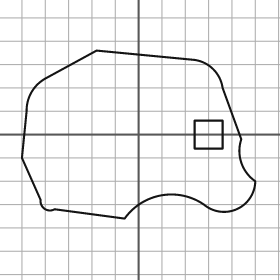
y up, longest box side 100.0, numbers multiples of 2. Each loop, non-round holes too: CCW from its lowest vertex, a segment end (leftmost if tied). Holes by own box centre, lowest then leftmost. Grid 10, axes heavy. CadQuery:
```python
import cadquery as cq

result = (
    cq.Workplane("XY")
    .moveTo(-6.0, -36.0)
    .threePointArc((10.0, -26.0), (28.0, -30.0))
    .threePointArc((42.0, -32.0), (50.0, -20.0))
    .threePointArc((44.0, -12.0), (44.0, -2.0))
    .lineTo(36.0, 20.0)
    .threePointArc((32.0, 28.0), (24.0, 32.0))
    .lineTo(-18.0, 36.0)
    .lineTo(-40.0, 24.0)
    .threePointArc((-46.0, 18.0), (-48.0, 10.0))
    .lineTo(-50.0, -10.0)
    .lineTo(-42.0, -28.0)
    .threePointArc((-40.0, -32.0), (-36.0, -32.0))
    .close()
    .moveTo(24.0, -6.0)
    .lineTo(36.0, -6.0)
    .lineTo(36.0, 6.0)
    .lineTo(24.0, 6.0)
    .close()
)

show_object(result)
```